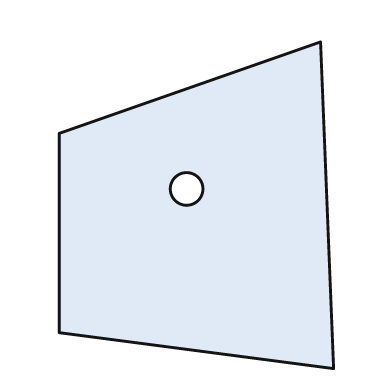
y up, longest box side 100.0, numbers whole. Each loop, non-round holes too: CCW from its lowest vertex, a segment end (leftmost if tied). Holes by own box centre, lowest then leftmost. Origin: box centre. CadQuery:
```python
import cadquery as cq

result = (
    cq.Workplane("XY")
    .moveTo(42.0, -50.0)
    .lineTo(38.0, 50.0)
    .lineTo(-42.0, 22.0)
    .lineTo(-42.0, -39.0)
    .close()
    .moveTo(-3.0, 5.0)
    .circle(5.0)
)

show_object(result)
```